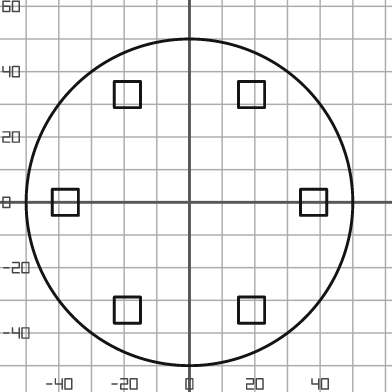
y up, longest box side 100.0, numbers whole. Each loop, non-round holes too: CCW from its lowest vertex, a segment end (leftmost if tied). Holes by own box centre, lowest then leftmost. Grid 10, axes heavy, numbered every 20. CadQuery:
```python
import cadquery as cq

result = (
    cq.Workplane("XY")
    .moveTo(0.0, 0.0)
    .circle(50.0)
    .moveTo(-23.0, -37.0)
    .lineTo(-15.0, -37.0)
    .lineTo(-15.0, -29.0)
    .lineTo(-23.0, -29.0)
    .close()
    .moveTo(15.0, -37.0)
    .lineTo(23.0, -37.0)
    .lineTo(23.0, -29.0)
    .lineTo(15.0, -29.0)
    .close()
    .moveTo(-42.0, -4.0)
    .lineTo(-34.0, -4.0)
    .lineTo(-34.0, 4.0)
    .lineTo(-42.0, 4.0)
    .close()
    .moveTo(34.0, -4.0)
    .lineTo(42.0, -4.0)
    .lineTo(42.0, 4.0)
    .lineTo(34.0, 4.0)
    .close()
    .moveTo(-23.0, 29.0)
    .lineTo(-15.0, 29.0)
    .lineTo(-15.0, 37.0)
    .lineTo(-23.0, 37.0)
    .close()
    .moveTo(15.0, 29.0)
    .lineTo(23.0, 29.0)
    .lineTo(23.0, 37.0)
    .lineTo(15.0, 37.0)
    .close()
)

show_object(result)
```